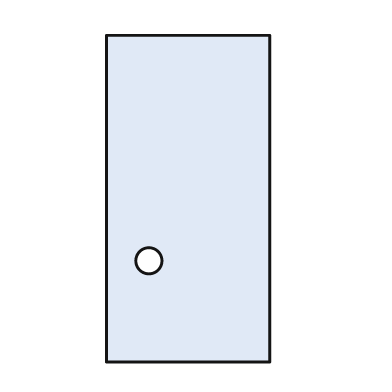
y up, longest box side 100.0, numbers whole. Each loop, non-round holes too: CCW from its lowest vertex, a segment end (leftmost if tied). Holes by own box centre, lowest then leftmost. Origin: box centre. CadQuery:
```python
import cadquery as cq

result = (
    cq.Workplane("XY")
    .moveTo(-25.0, -50.0)
    .lineTo(25.0, -50.0)
    .lineTo(25.0, 50.0)
    .lineTo(-25.0, 50.0)
    .close()
    .moveTo(-12.0, -19.0)
    .circle(4.0)
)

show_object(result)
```